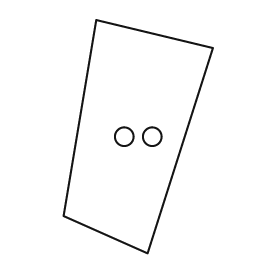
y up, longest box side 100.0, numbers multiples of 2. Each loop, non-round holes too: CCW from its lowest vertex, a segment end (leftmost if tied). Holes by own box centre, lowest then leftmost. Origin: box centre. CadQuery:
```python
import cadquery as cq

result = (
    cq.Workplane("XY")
    .moveTo(4.0, -50.0)
    .lineTo(32.0, 38.0)
    .lineTo(-18.0, 50.0)
    .lineTo(-32.0, -34.0)
    .close()
    .moveTo(-6.0, 0.0)
    .circle(4.0)
    .moveTo(6.0, 0.0)
    .circle(4.0)
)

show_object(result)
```